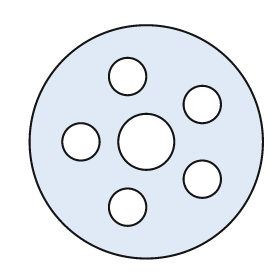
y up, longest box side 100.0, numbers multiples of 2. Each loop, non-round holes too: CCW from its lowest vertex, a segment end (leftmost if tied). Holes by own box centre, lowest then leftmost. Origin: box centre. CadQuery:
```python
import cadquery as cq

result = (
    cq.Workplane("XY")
    .moveTo(0.0, 0.0)
    .circle(50.0)
    .moveTo(-8.0, -28.0)
    .circle(8.0)
    .moveTo(24.0, -16.0)
    .circle(8.0)
    .moveTo(-28.0, 0.0)
    .circle(8.0)
    .moveTo(0.0, 0.0)
    .circle(12.0)
    .moveTo(24.0, 16.0)
    .circle(8.0)
    .moveTo(-8.0, 28.0)
    .circle(8.0)
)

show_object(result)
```